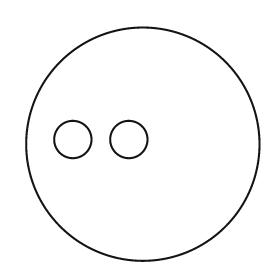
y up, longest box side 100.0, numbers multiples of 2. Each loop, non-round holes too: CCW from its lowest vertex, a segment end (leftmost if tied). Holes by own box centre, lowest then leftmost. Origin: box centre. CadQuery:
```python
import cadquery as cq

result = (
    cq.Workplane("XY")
    .moveTo(0.0, 0.0)
    .circle(50.0)
    .moveTo(-30.0, 2.0)
    .circle(8.0)
    .moveTo(-6.0, 2.0)
    .circle(8.0)
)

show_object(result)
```